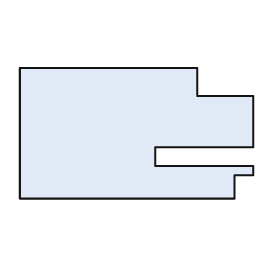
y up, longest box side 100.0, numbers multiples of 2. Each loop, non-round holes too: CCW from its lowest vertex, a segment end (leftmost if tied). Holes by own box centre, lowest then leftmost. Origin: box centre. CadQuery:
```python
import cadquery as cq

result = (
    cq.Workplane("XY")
    .moveTo(-50.0, -28.0)
    .lineTo(42.0, -28.0)
    .lineTo(42.0, -18.0)
    .lineTo(50.0, -18.0)
    .lineTo(50.0, -14.0)
    .lineTo(8.0, -14.0)
    .lineTo(8.0, -6.0)
    .lineTo(50.0, -6.0)
    .lineTo(50.0, 16.0)
    .lineTo(26.0, 16.0)
    .lineTo(26.0, 28.0)
    .lineTo(-50.0, 28.0)
    .close()
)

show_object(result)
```